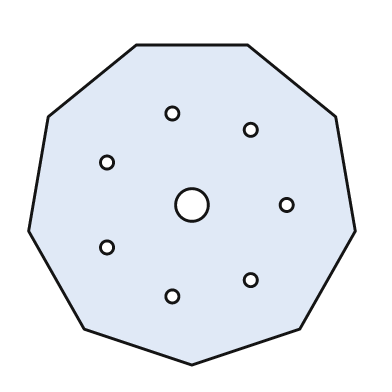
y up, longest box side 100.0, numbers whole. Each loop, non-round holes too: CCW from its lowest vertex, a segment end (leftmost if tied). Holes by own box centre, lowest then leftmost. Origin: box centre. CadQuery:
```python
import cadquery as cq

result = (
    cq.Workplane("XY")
    .moveTo(0.0, -49.0)
    .lineTo(33.0, -38.0)
    .lineTo(50.0, -8.0)
    .lineTo(44.0, 27.0)
    .lineTo(17.0, 49.0)
    .lineTo(-17.0, 49.0)
    .lineTo(-44.0, 27.0)
    .lineTo(-50.0, -8.0)
    .lineTo(-33.0, -38.0)
    .close()
    .moveTo(-6.0, -28.0)
    .circle(2.0)
    .moveTo(18.0, -23.0)
    .circle(2.0)
    .moveTo(-26.0, -13.0)
    .circle(2.0)
    .moveTo(0.0, 0.0)
    .circle(5.0)
    .moveTo(29.0, 0.0)
    .circle(2.0)
    .moveTo(-26.0, 13.0)
    .circle(2.0)
    .moveTo(18.0, 23.0)
    .circle(2.0)
    .moveTo(-6.0, 28.0)
    .circle(2.0)
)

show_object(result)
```